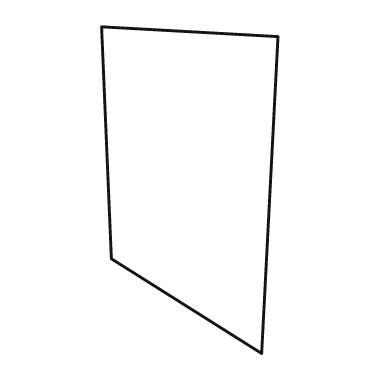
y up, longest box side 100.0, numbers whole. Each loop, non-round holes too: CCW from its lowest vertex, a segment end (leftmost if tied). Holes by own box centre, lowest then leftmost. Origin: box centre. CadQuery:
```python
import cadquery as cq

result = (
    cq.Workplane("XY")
    .moveTo(22.0, -50.0)
    .lineTo(27.0, 47.0)
    .lineTo(-27.0, 50.0)
    .lineTo(-24.0, -21.0)
    .close()
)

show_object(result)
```